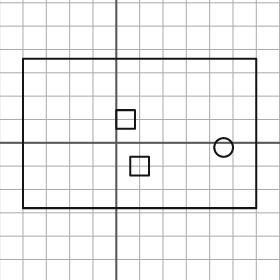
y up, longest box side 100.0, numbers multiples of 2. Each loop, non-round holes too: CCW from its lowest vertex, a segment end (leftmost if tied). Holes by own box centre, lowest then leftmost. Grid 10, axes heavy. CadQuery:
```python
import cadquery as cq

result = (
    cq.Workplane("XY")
    .moveTo(-40.0, -28.0)
    .lineTo(60.0, -28.0)
    .lineTo(60.0, 36.0)
    .lineTo(-40.0, 36.0)
    .close()
    .moveTo(6.0, -14.0)
    .lineTo(14.0, -14.0)
    .lineTo(14.0, -6.0)
    .lineTo(6.0, -6.0)
    .close()
    .moveTo(46.0, -2.0)
    .circle(4.0)
    .moveTo(0.0, 6.0)
    .lineTo(8.0, 6.0)
    .lineTo(8.0, 14.0)
    .lineTo(0.0, 14.0)
    .close()
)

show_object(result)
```